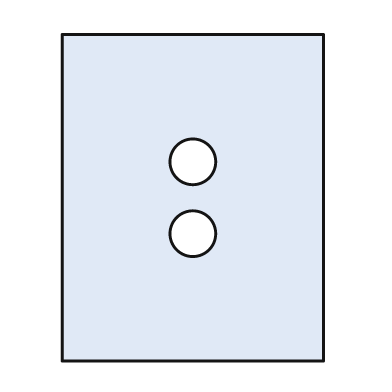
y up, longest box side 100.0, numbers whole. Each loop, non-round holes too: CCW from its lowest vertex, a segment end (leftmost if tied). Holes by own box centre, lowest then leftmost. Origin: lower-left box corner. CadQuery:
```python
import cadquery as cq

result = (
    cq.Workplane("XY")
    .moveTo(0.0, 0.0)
    .lineTo(80.0, 0.0)
    .lineTo(80.0, 100.0)
    .lineTo(0.0, 100.0)
    .close()
    .moveTo(40.0, 39.0)
    .circle(7.0)
    .moveTo(40.0, 61.0)
    .circle(7.0)
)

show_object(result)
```